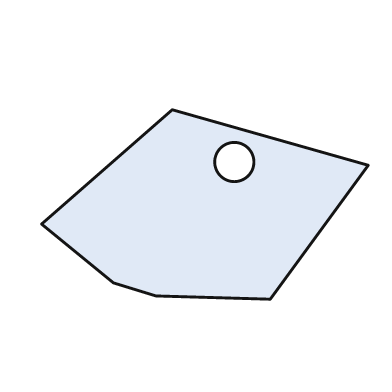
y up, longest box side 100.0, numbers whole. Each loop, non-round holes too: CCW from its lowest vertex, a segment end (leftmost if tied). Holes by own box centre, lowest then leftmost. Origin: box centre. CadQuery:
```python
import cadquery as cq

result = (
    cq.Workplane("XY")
    .moveTo(20.0, -29.0)
    .lineTo(50.0, 12.0)
    .lineTo(-10.0, 29.0)
    .lineTo(-50.0, -6.0)
    .lineTo(-28.0, -24.0)
    .lineTo(-15.0, -28.0)
    .close()
    .moveTo(9.0, 13.0)
    .circle(6.0)
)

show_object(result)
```